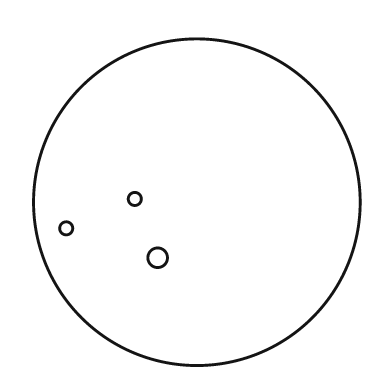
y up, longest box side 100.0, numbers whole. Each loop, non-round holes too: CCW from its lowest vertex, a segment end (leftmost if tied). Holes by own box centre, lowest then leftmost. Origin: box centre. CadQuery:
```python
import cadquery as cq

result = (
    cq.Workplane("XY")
    .moveTo(0.0, 0.0)
    .circle(50.0)
    .moveTo(-12.0, -17.0)
    .circle(3.0)
    .moveTo(-40.0, -8.0)
    .circle(2.0)
    .moveTo(-19.0, 1.0)
    .circle(2.0)
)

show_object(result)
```